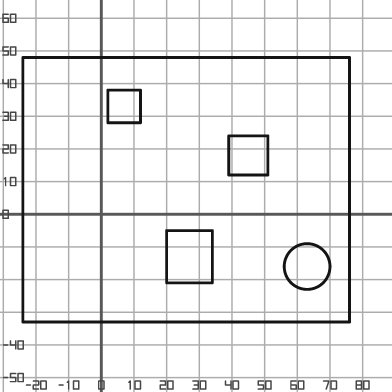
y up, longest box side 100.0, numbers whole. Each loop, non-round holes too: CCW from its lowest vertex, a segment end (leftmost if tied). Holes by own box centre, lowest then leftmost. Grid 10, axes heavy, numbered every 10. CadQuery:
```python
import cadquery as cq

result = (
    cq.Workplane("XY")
    .moveTo(-24.0, -33.0)
    .lineTo(76.0, -33.0)
    .lineTo(76.0, 48.0)
    .lineTo(-24.0, 48.0)
    .close()
    .moveTo(63.0, -16.0)
    .circle(7.0)
    .moveTo(20.0, -21.0)
    .lineTo(34.0, -21.0)
    .lineTo(34.0, -5.0)
    .lineTo(20.0, -5.0)
    .close()
    .moveTo(39.0, 12.0)
    .lineTo(51.0, 12.0)
    .lineTo(51.0, 24.0)
    .lineTo(39.0, 24.0)
    .close()
    .moveTo(2.0, 28.0)
    .lineTo(12.0, 28.0)
    .lineTo(12.0, 38.0)
    .lineTo(2.0, 38.0)
    .close()
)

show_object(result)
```